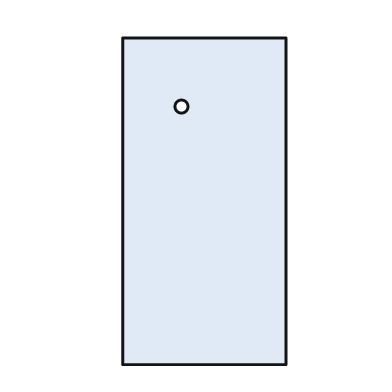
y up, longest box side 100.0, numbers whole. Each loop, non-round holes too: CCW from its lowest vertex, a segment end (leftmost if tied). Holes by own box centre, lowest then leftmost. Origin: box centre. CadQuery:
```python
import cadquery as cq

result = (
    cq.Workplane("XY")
    .moveTo(-25.0, -50.0)
    .lineTo(25.0, -50.0)
    .lineTo(25.0, 50.0)
    .lineTo(-25.0, 50.0)
    .close()
    .moveTo(-7.0, 29.0)
    .circle(2.0)
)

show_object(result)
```